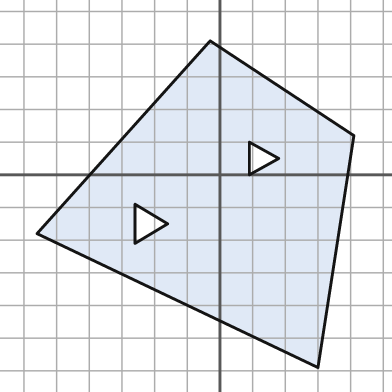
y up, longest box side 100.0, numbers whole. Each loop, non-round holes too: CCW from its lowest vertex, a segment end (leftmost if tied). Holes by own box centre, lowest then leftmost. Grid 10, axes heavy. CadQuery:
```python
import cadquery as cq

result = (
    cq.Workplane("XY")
    .moveTo(30.0, -59.0)
    .lineTo(41.0, 12.0)
    .lineTo(-3.0, 41.0)
    .lineTo(-56.0, -18.0)
    .close()
    .moveTo(-26.0, -21.0)
    .lineTo(-16.0, -15.0)
    .lineTo(-26.0, -9.0)
    .close()
    .moveTo(9.0, 0.0)
    .lineTo(18.0, 5.0)
    .lineTo(9.0, 10.0)
    .close()
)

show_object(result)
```